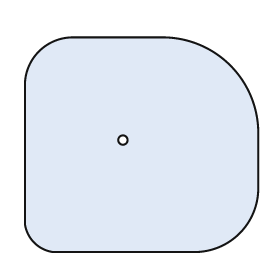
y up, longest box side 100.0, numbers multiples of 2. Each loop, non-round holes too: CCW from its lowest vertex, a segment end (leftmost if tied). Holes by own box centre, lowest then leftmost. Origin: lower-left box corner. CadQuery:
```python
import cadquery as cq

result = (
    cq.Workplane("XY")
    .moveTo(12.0, 0.0)
    .lineTo(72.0, 0.0)
    .threePointArc((92.0, 8.0), (100.0, 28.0))
    .lineTo(100.0, 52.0)
    .threePointArc((88.0, 80.0), (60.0, 92.0))
    .lineTo(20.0, 92.0)
    .threePointArc((6.0, 86.0), (0.0, 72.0))
    .lineTo(0.0, 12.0)
    .threePointArc((4.0, 4.0), (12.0, 0.0))
    .close()
    .moveTo(42.0, 48.0)
    .circle(2.0)
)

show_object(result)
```